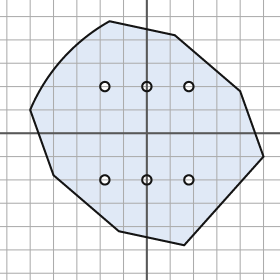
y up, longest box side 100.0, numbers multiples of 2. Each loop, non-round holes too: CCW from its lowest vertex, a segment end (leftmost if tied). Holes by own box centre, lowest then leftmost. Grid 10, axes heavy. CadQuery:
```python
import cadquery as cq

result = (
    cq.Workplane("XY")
    .moveTo(16.0, -48.0)
    .lineTo(50.0, -10.0)
    .lineTo(40.0, 18.0)
    .lineTo(12.0, 42.0)
    .lineTo(-16.0, 48.0)
    .threePointArc((-36.0, 32.0), (-50.0, 10.0))
    .lineTo(-40.0, -18.0)
    .lineTo(-12.0, -42.0)
    .close()
    .moveTo(-18.0, -20.0)
    .circle(2.0)
    .moveTo(0.0, -20.0)
    .circle(2.0)
    .moveTo(18.0, -20.0)
    .circle(2.0)
    .moveTo(-18.0, 20.0)
    .circle(2.0)
    .moveTo(0.0, 20.0)
    .circle(2.0)
    .moveTo(18.0, 20.0)
    .circle(2.0)
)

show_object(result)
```